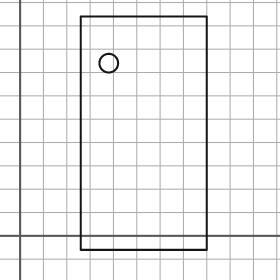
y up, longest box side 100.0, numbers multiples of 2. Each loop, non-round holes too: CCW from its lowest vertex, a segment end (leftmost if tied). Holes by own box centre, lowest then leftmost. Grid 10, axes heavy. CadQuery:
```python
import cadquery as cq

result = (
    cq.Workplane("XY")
    .moveTo(26.0, -6.0)
    .lineTo(80.0, -6.0)
    .lineTo(80.0, 94.0)
    .lineTo(26.0, 94.0)
    .close()
    .moveTo(38.0, 74.0)
    .circle(4.0)
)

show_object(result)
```